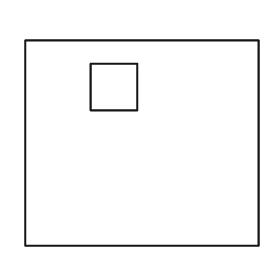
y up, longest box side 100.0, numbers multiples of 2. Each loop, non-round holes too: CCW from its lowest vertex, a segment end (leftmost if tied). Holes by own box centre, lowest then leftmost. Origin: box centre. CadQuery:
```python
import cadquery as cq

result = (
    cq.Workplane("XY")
    .moveTo(-50.0, -44.0)
    .lineTo(50.0, -44.0)
    .lineTo(50.0, 44.0)
    .lineTo(-50.0, 44.0)
    .close()
    .moveTo(-22.0, 14.0)
    .lineTo(-2.0, 14.0)
    .lineTo(-2.0, 34.0)
    .lineTo(-22.0, 34.0)
    .close()
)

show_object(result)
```